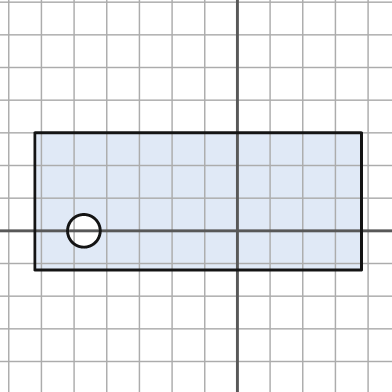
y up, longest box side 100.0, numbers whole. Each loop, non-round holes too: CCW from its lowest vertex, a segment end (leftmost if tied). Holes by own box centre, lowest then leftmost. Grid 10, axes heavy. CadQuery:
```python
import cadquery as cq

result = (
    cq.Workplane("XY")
    .moveTo(-62.0, -12.0)
    .lineTo(38.0, -12.0)
    .lineTo(38.0, 30.0)
    .lineTo(-62.0, 30.0)
    .close()
    .moveTo(-47.0, 0.0)
    .circle(5.0)
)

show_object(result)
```